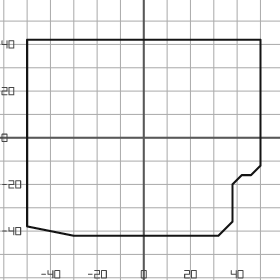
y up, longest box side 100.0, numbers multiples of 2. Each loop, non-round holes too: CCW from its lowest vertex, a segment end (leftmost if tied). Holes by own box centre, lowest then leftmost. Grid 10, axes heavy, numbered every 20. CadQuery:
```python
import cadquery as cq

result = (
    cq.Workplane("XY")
    .moveTo(-30.0, -42.0)
    .lineTo(32.0, -42.0)
    .lineTo(38.0, -36.0)
    .lineTo(38.0, -20.0)
    .lineTo(42.0, -16.0)
    .lineTo(46.0, -16.0)
    .lineTo(50.0, -12.0)
    .lineTo(50.0, 42.0)
    .lineTo(-50.0, 42.0)
    .lineTo(-50.0, -38.0)
    .close()
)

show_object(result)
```